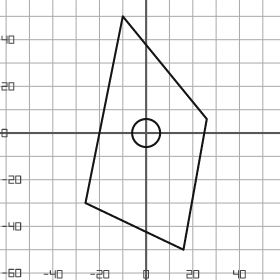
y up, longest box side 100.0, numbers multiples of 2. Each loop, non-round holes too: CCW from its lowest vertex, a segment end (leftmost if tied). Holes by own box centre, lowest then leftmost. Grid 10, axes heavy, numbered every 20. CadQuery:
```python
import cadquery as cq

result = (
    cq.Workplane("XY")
    .moveTo(16.0, -50.0)
    .lineTo(26.0, 6.0)
    .lineTo(-10.0, 50.0)
    .lineTo(-26.0, -30.0)
    .close()
    .moveTo(0.0, 0.0)
    .circle(6.0)
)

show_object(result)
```